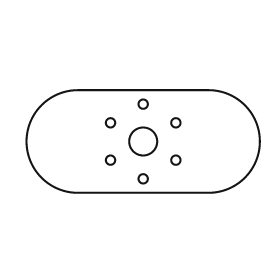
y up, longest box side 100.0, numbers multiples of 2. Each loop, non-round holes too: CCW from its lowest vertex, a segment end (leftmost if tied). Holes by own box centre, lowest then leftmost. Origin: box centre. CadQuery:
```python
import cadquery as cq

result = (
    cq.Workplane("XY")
    .moveTo(-28.0, -22.0)
    .lineTo(28.0, -22.0)
    .threePointArc((50.0, 0.0), (28.0, 22.0))
    .lineTo(-28.0, 22.0)
    .threePointArc((-50.0, 0.0), (-28.0, -22.0))
    .close()
    .moveTo(0.0, -16.0)
    .circle(2.0)
    .moveTo(-14.0, -8.0)
    .circle(2.0)
    .moveTo(14.0, -8.0)
    .circle(2.0)
    .moveTo(0.0, 0.0)
    .circle(6.0)
    .moveTo(-14.0, 8.0)
    .circle(2.0)
    .moveTo(14.0, 8.0)
    .circle(2.0)
    .moveTo(0.0, 16.0)
    .circle(2.0)
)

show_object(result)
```